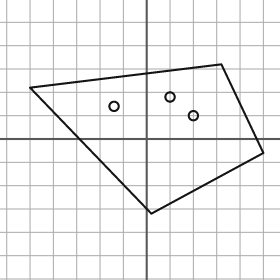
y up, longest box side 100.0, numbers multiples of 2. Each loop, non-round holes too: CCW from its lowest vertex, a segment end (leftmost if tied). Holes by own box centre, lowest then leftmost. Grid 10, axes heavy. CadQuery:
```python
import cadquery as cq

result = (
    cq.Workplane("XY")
    .moveTo(2.0, -32.0)
    .lineTo(50.0, -6.0)
    .lineTo(32.0, 32.0)
    .lineTo(-50.0, 22.0)
    .close()
    .moveTo(20.0, 10.0)
    .circle(2.0)
    .moveTo(-14.0, 14.0)
    .circle(2.0)
    .moveTo(10.0, 18.0)
    .circle(2.0)
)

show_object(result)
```